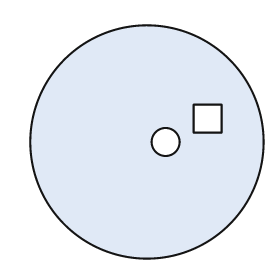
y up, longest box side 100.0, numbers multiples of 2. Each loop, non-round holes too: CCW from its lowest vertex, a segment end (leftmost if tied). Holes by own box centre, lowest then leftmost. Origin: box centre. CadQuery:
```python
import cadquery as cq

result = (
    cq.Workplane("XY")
    .moveTo(0.0, 0.0)
    .circle(50.0)
    .moveTo(8.0, 0.0)
    .circle(6.0)
    .moveTo(20.0, 4.0)
    .lineTo(32.0, 4.0)
    .lineTo(32.0, 16.0)
    .lineTo(20.0, 16.0)
    .close()
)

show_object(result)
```